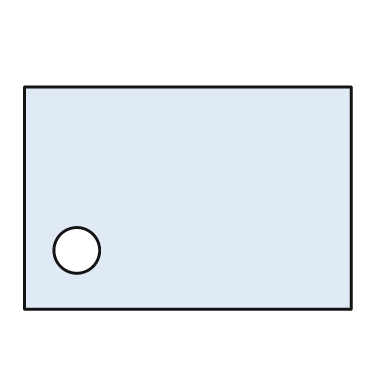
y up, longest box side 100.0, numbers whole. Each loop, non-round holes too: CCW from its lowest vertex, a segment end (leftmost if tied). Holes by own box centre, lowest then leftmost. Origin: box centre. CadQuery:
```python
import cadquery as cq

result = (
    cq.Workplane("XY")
    .moveTo(-50.0, -34.0)
    .lineTo(50.0, -34.0)
    .lineTo(50.0, 34.0)
    .lineTo(-50.0, 34.0)
    .close()
    .moveTo(-34.0, -16.0)
    .circle(7.0)
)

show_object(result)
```